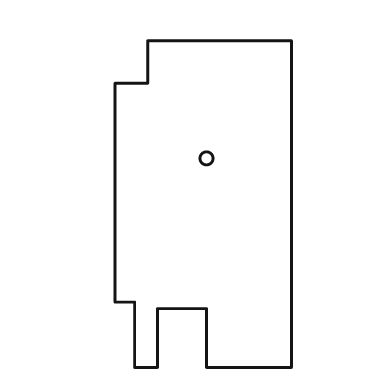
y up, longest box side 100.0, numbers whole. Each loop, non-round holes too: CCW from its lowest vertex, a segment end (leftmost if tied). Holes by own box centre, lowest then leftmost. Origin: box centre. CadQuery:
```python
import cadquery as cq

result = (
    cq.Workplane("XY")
    .moveTo(-21.0, -50.0)
    .lineTo(-14.0, -50.0)
    .lineTo(-14.0, -32.0)
    .lineTo(1.0, -32.0)
    .lineTo(1.0, -50.0)
    .lineTo(27.0, -50.0)
    .lineTo(27.0, 50.0)
    .lineTo(-17.0, 50.0)
    .lineTo(-17.0, 37.0)
    .lineTo(-27.0, 37.0)
    .lineTo(-27.0, -30.0)
    .lineTo(-21.0, -30.0)
    .close()
    .moveTo(1.0, 14.0)
    .circle(2.0)
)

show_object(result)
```